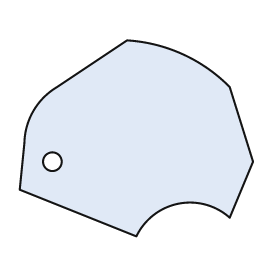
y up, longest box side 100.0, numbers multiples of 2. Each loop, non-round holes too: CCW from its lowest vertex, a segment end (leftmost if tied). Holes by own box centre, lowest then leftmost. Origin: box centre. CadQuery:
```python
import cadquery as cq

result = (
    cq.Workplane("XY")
    .moveTo(0.0, -42.0)
    .threePointArc((18.0, -28.0), (40.0, -34.0))
    .lineTo(50.0, -10.0)
    .lineTo(40.0, 22.0)
    .threePointArc((20.0, 36.0), (-4.0, 42.0))
    .lineTo(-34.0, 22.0)
    .threePointArc((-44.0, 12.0), (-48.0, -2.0))
    .lineTo(-50.0, -22.0)
    .close()
    .moveTo(-36.0, -10.0)
    .circle(4.0)
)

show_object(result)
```